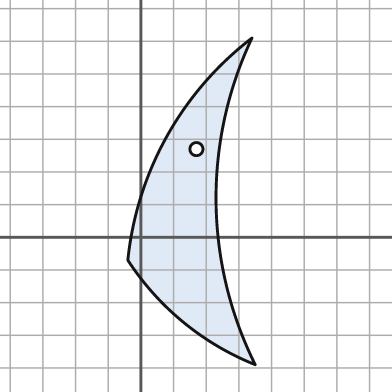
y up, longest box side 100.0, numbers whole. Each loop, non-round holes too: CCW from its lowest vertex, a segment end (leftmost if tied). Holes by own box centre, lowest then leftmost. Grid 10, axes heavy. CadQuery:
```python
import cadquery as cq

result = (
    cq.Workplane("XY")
    .moveTo(35.0, -39.0)
    .threePointArc((23.0, 11.0), (34.0, 61.0))
    .threePointArc((8.0, 31.0), (-4.0, -7.0))
    .threePointArc((13.0, -26.0), (35.0, -39.0))
    .close()
    .moveTo(17.0, 27.0)
    .circle(2.0)
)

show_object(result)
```